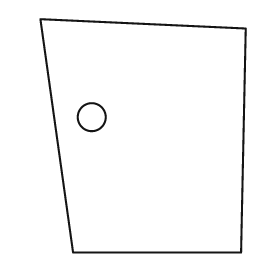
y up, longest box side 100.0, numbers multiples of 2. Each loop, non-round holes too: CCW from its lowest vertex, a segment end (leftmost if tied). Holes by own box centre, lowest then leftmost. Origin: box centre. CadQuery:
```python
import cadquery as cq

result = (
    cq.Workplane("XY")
    .moveTo(-30.0, -50.0)
    .lineTo(42.0, -50.0)
    .lineTo(44.0, 46.0)
    .lineTo(-44.0, 50.0)
    .close()
    .moveTo(-22.0, 8.0)
    .circle(6.0)
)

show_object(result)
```